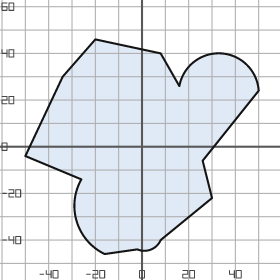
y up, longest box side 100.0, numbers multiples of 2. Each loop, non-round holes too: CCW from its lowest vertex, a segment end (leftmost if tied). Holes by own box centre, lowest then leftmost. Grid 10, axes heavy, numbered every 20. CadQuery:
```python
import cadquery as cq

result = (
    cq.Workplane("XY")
    .moveTo(-16.0, -46.0)
    .lineTo(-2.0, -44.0)
    .threePointArc((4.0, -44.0), (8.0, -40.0))
    .lineTo(30.0, -22.0)
    .lineTo(26.0, -6.0)
    .lineTo(50.0, 24.0)
    .threePointArc((34.0, 40.0), (16.0, 26.0))
    .lineTo(8.0, 40.0)
    .lineTo(-20.0, 46.0)
    .lineTo(-34.0, 30.0)
    .lineTo(-50.0, -4.0)
    .lineTo(-26.0, -14.0)
    .threePointArc((-28.0, -32.0), (-16.0, -46.0))
    .close()
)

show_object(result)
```